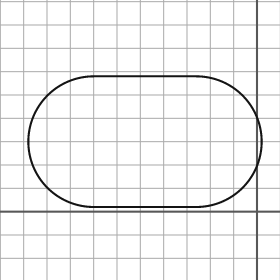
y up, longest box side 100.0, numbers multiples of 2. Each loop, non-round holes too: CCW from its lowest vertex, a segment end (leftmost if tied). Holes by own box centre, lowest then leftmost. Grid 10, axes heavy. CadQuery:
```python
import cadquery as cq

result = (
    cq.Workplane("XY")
    .moveTo(-70.0, 2.0)
    .lineTo(-26.0, 2.0)
    .threePointArc((2.0, 30.0), (-26.0, 58.0))
    .lineTo(-70.0, 58.0)
    .threePointArc((-98.0, 30.0), (-70.0, 2.0))
    .close()
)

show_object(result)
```